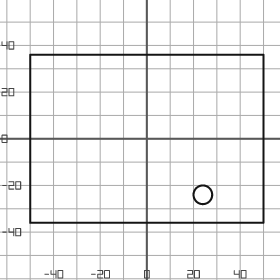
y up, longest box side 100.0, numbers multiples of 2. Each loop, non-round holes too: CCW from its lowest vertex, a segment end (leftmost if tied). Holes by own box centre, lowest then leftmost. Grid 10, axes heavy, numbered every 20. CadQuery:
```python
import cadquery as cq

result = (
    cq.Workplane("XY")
    .moveTo(-50.0, -36.0)
    .lineTo(50.0, -36.0)
    .lineTo(50.0, 36.0)
    .lineTo(-50.0, 36.0)
    .close()
    .moveTo(24.0, -24.0)
    .circle(4.0)
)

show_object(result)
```